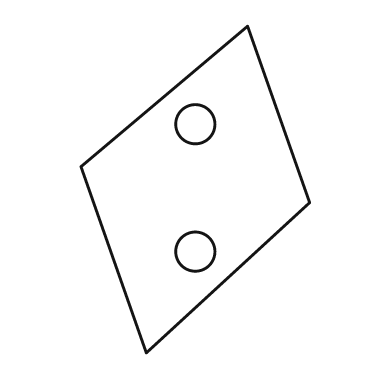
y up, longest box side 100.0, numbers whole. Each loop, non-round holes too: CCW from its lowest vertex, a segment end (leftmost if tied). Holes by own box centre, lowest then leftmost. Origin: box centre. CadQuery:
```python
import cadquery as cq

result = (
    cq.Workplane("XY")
    .moveTo(-15.0, -50.0)
    .lineTo(35.0, -4.0)
    .lineTo(16.0, 50.0)
    .lineTo(-35.0, 7.0)
    .close()
    .moveTo(0.0, -19.0)
    .circle(6.0)
    .moveTo(0.0, 20.0)
    .circle(6.0)
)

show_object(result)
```